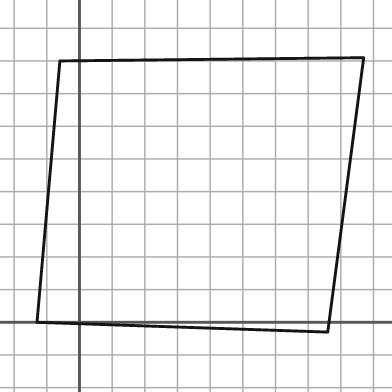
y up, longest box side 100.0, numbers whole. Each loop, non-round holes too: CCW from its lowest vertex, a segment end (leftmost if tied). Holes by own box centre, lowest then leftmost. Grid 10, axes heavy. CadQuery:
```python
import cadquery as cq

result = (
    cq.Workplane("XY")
    .moveTo(76.0, -3.0)
    .lineTo(87.0, 81.0)
    .lineTo(-6.0, 80.0)
    .lineTo(-13.0, 0.0)
    .close()
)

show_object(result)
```